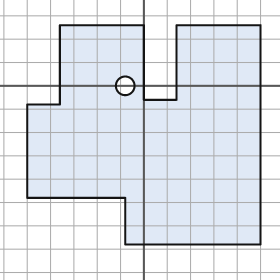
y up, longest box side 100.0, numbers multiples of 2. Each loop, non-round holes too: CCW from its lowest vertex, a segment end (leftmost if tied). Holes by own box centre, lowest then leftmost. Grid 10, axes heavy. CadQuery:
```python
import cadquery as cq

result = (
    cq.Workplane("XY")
    .moveTo(-8.0, -68.0)
    .lineTo(50.0, -68.0)
    .lineTo(50.0, 26.0)
    .lineTo(14.0, 26.0)
    .lineTo(14.0, -6.0)
    .lineTo(0.0, -6.0)
    .lineTo(0.0, 26.0)
    .lineTo(-36.0, 26.0)
    .lineTo(-36.0, -8.0)
    .lineTo(-50.0, -8.0)
    .lineTo(-50.0, -48.0)
    .lineTo(-8.0, -48.0)
    .close()
    .moveTo(-8.0, 0.0)
    .circle(4.0)
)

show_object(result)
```